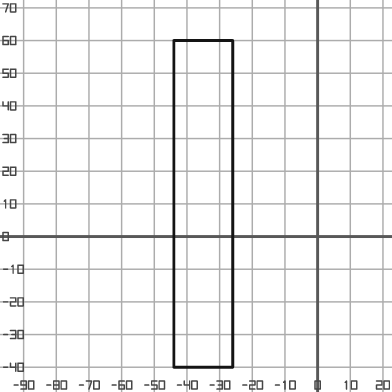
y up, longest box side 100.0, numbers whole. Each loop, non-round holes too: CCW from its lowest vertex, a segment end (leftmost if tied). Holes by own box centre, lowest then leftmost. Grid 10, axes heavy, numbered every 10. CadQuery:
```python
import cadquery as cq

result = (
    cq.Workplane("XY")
    .moveTo(-44.0, -40.0)
    .lineTo(-26.0, -40.0)
    .lineTo(-26.0, 60.0)
    .lineTo(-44.0, 60.0)
    .close()
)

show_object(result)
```